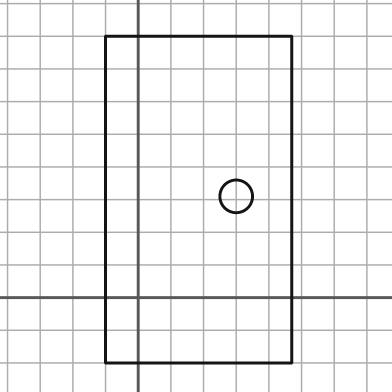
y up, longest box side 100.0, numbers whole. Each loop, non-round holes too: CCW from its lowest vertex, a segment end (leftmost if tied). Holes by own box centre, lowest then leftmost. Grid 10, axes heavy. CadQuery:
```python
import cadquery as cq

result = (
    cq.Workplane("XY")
    .moveTo(-10.0, -20.0)
    .lineTo(47.0, -20.0)
    .lineTo(47.0, 80.0)
    .lineTo(-10.0, 80.0)
    .close()
    .moveTo(30.0, 31.0)
    .circle(5.0)
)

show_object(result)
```